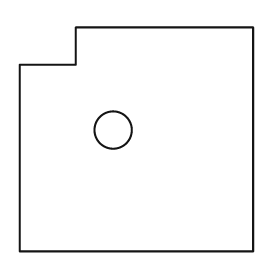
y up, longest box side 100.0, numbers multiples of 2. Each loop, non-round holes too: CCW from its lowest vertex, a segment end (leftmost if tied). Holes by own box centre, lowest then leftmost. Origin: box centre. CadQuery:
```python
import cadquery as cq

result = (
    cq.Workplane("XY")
    .moveTo(-50.0, -48.0)
    .lineTo(50.0, -48.0)
    .lineTo(50.0, 48.0)
    .lineTo(-26.0, 48.0)
    .lineTo(-26.0, 32.0)
    .lineTo(-50.0, 32.0)
    .close()
    .moveTo(-10.0, 4.0)
    .circle(8.0)
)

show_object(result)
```